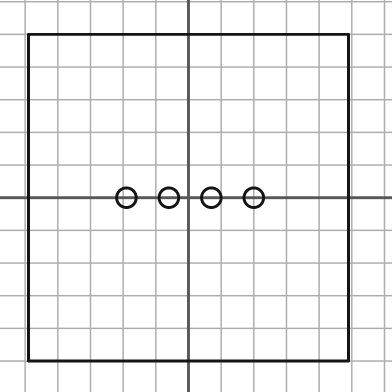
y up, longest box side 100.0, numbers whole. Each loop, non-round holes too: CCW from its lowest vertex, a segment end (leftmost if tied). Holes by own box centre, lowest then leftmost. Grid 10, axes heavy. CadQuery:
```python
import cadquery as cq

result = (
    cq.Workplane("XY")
    .moveTo(-49.0, -50.0)
    .lineTo(49.0, -50.0)
    .lineTo(49.0, 50.0)
    .lineTo(-49.0, 50.0)
    .close()
    .moveTo(-19.0, 0.0)
    .circle(3.0)
    .moveTo(-6.0, 0.0)
    .circle(3.0)
    .moveTo(7.0, 0.0)
    .circle(3.0)
    .moveTo(20.0, 0.0)
    .circle(3.0)
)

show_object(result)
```